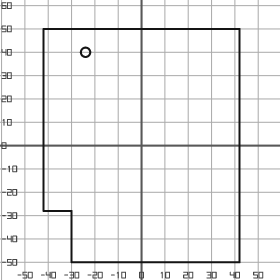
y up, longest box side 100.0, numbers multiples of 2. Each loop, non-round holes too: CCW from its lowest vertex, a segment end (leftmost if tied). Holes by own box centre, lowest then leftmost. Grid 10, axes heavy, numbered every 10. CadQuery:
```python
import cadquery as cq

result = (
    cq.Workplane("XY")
    .moveTo(-30.0, -50.0)
    .lineTo(42.0, -50.0)
    .lineTo(42.0, 50.0)
    .lineTo(-42.0, 50.0)
    .lineTo(-42.0, -28.0)
    .lineTo(-30.0, -28.0)
    .close()
    .moveTo(-24.0, 40.0)
    .circle(2.0)
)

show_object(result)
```